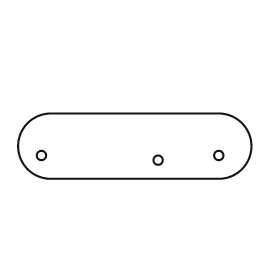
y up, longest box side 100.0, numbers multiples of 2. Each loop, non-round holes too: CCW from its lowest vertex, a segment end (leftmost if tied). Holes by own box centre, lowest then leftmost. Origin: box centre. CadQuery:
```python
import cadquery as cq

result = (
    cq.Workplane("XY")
    .moveTo(-36.0, -14.0)
    .lineTo(36.0, -14.0)
    .threePointArc((50.0, 0.0), (36.0, 14.0))
    .lineTo(-36.0, 14.0)
    .threePointArc((-50.0, 0.0), (-36.0, -14.0))
    .close()
    .moveTo(10.0, -6.0)
    .circle(2.0)
    .moveTo(-40.0, -4.0)
    .circle(2.0)
    .moveTo(36.0, -4.0)
    .circle(2.0)
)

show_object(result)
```